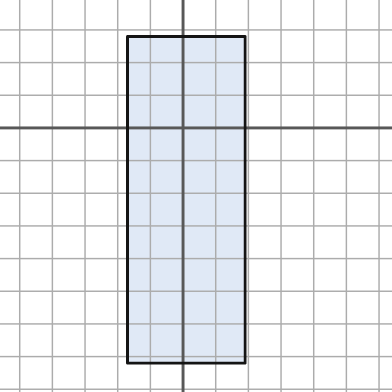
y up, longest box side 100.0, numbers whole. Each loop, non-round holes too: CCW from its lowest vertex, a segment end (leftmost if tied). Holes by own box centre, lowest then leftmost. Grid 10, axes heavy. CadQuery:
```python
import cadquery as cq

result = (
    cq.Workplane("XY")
    .moveTo(-17.0, -72.0)
    .lineTo(19.0, -72.0)
    .lineTo(19.0, 28.0)
    .lineTo(-17.0, 28.0)
    .close()
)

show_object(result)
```